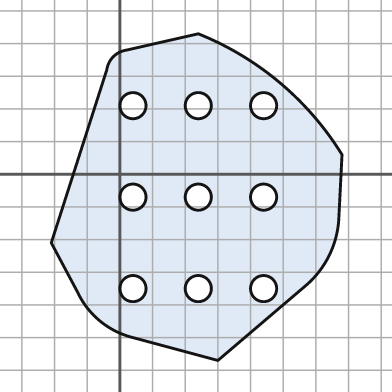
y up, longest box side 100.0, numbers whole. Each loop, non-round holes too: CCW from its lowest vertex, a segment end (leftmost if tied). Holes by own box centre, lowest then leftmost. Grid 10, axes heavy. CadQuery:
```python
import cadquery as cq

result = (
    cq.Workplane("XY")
    .moveTo(30.0, -57.0)
    .lineTo(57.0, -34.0)
    .threePointArc((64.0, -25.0), (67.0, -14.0))
    .lineTo(68.0, 6.0)
    .threePointArc((49.0, 28.0), (24.0, 43.0))
    .lineTo(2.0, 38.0)
    .threePointArc((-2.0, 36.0), (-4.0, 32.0))
    .lineTo(-21.0, -21.0)
    .lineTo(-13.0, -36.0)
    .threePointArc((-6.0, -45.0), (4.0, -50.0))
    .close()
    .moveTo(4.0, -35.0)
    .circle(4.0)
    .moveTo(24.0, -35.0)
    .circle(4.0)
    .moveTo(44.0, -35.0)
    .circle(4.0)
    .moveTo(4.0, -7.0)
    .circle(4.0)
    .moveTo(24.0, -7.0)
    .circle(4.0)
    .moveTo(44.0, -7.0)
    .circle(4.0)
    .moveTo(4.0, 21.0)
    .circle(4.0)
    .moveTo(24.0, 21.0)
    .circle(4.0)
    .moveTo(44.0, 21.0)
    .circle(4.0)
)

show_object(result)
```